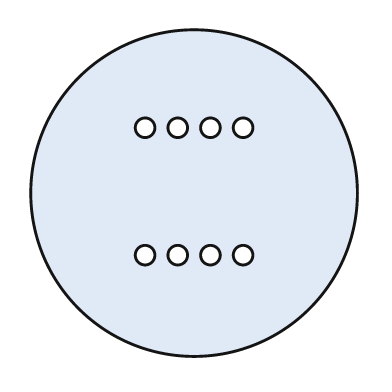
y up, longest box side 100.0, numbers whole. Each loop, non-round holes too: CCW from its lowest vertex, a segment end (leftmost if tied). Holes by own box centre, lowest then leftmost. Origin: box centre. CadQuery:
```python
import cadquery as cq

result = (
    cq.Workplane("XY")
    .moveTo(0.0, 0.0)
    .circle(50.0)
    .moveTo(-15.0, -19.0)
    .circle(3.0)
    .moveTo(-5.0, -19.0)
    .circle(3.0)
    .moveTo(5.0, -19.0)
    .circle(3.0)
    .moveTo(15.0, -19.0)
    .circle(3.0)
    .moveTo(-15.0, 20.0)
    .circle(3.0)
    .moveTo(-5.0, 20.0)
    .circle(3.0)
    .moveTo(5.0, 20.0)
    .circle(3.0)
    .moveTo(15.0, 20.0)
    .circle(3.0)
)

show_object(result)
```